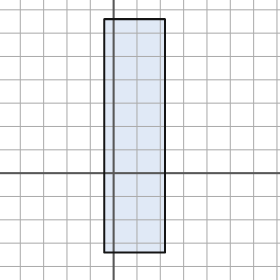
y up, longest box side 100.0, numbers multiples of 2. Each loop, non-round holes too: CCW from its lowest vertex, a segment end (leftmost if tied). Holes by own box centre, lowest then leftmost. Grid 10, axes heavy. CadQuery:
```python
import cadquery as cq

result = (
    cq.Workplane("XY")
    .moveTo(-4.0, -34.0)
    .lineTo(22.0, -34.0)
    .lineTo(22.0, 66.0)
    .lineTo(-4.0, 66.0)
    .close()
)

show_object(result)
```